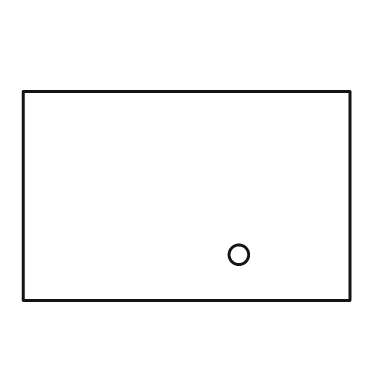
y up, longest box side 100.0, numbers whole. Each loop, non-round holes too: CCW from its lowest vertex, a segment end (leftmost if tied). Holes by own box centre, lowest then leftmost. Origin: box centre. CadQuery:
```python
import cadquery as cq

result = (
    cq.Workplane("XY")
    .moveTo(-50.0, -32.0)
    .lineTo(50.0, -32.0)
    .lineTo(50.0, 32.0)
    .lineTo(-50.0, 32.0)
    .close()
    .moveTo(16.0, -18.0)
    .circle(3.0)
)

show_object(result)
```